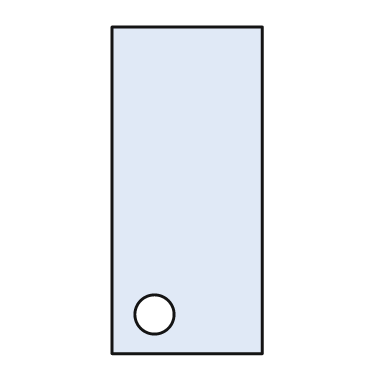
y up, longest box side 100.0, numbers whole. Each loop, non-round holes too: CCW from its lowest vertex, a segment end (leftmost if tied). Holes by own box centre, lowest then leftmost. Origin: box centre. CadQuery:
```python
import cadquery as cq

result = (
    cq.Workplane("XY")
    .moveTo(-23.0, -50.0)
    .lineTo(23.0, -50.0)
    .lineTo(23.0, 50.0)
    .lineTo(-23.0, 50.0)
    .close()
    .moveTo(-10.0, -38.0)
    .circle(6.0)
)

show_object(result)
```